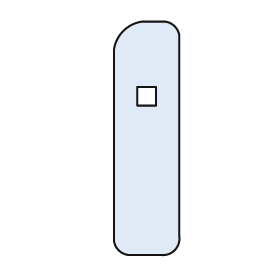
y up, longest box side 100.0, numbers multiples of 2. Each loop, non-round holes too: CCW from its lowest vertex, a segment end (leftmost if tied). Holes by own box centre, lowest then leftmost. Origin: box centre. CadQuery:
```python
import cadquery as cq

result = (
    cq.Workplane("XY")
    .moveTo(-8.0, -50.0)
    .lineTo(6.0, -50.0)
    .threePointArc((12.0, -48.0), (14.0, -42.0))
    .lineTo(14.0, 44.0)
    .threePointArc((12.0, 48.0), (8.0, 50.0))
    .lineTo(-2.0, 50.0)
    .threePointArc((-10.0, 46.0), (-14.0, 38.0))
    .lineTo(-14.0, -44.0)
    .threePointArc((-12.0, -48.0), (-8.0, -50.0))
    .close()
    .moveTo(-4.0, 14.0)
    .lineTo(4.0, 14.0)
    .lineTo(4.0, 22.0)
    .lineTo(-4.0, 22.0)
    .close()
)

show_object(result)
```